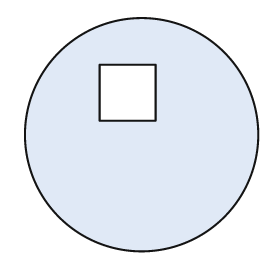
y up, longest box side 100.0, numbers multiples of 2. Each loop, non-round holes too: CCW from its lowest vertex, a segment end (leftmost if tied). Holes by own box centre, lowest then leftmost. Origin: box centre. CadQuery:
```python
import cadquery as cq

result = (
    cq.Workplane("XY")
    .moveTo(0.0, 0.0)
    .circle(50.0)
    .moveTo(-18.0, 6.0)
    .lineTo(6.0, 6.0)
    .lineTo(6.0, 30.0)
    .lineTo(-18.0, 30.0)
    .close()
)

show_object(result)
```